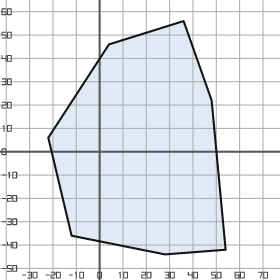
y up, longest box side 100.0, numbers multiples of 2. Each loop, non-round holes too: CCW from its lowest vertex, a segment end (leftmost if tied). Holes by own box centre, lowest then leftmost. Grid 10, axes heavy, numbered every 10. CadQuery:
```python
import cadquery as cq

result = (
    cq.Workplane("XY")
    .moveTo(28.0, -44.0)
    .lineTo(54.0, -42.0)
    .lineTo(48.0, 22.0)
    .lineTo(36.0, 56.0)
    .lineTo(4.0, 46.0)
    .lineTo(-22.0, 6.0)
    .lineTo(-12.0, -36.0)
    .close()
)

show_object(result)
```